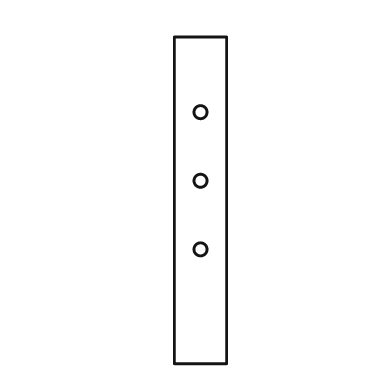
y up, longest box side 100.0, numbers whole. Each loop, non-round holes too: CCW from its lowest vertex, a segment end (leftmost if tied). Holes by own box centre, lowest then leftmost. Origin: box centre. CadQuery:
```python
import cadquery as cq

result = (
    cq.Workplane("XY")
    .moveTo(-8.0, -50.0)
    .lineTo(8.0, -50.0)
    .lineTo(8.0, 50.0)
    .lineTo(-8.0, 50.0)
    .close()
    .moveTo(0.0, -15.0)
    .circle(2.0)
    .moveTo(0.0, 6.0)
    .circle(2.0)
    .moveTo(0.0, 27.0)
    .circle(2.0)
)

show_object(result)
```